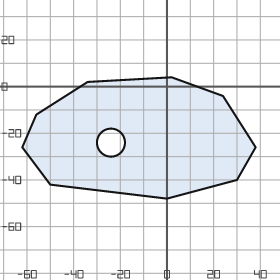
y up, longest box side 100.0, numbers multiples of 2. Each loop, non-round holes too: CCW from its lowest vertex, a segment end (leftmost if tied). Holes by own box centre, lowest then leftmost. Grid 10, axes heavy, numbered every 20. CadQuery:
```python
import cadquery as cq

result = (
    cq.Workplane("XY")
    .moveTo(0.0, -48.0)
    .lineTo(30.0, -40.0)
    .lineTo(38.0, -26.0)
    .lineTo(24.0, -4.0)
    .lineTo(2.0, 4.0)
    .lineTo(-34.0, 2.0)
    .lineTo(-56.0, -12.0)
    .lineTo(-62.0, -26.0)
    .lineTo(-50.0, -42.0)
    .close()
    .moveTo(-24.0, -24.0)
    .circle(6.0)
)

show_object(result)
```